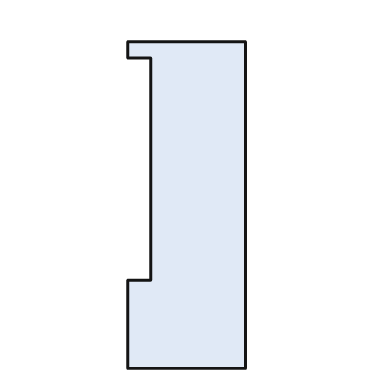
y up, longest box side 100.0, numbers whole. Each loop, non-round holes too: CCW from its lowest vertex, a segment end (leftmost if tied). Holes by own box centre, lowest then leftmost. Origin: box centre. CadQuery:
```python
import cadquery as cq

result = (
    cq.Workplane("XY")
    .moveTo(-18.0, -50.0)
    .lineTo(18.0, -50.0)
    .lineTo(18.0, 50.0)
    .lineTo(-18.0, 50.0)
    .lineTo(-18.0, 45.0)
    .lineTo(-11.0, 45.0)
    .lineTo(-11.0, -23.0)
    .lineTo(-18.0, -23.0)
    .close()
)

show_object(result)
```